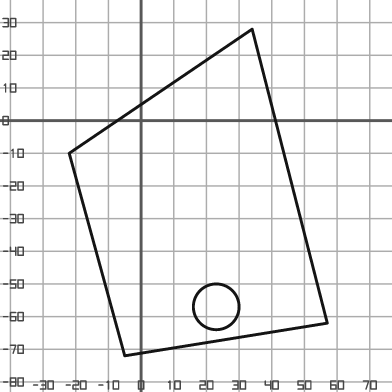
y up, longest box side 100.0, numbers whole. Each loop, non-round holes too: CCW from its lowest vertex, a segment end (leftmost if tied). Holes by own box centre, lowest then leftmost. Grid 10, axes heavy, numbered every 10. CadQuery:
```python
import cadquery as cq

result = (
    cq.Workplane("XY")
    .moveTo(-5.0, -72.0)
    .lineTo(57.0, -62.0)
    .lineTo(34.0, 28.0)
    .lineTo(-22.0, -10.0)
    .close()
    .moveTo(23.0, -57.0)
    .circle(7.0)
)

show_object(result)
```